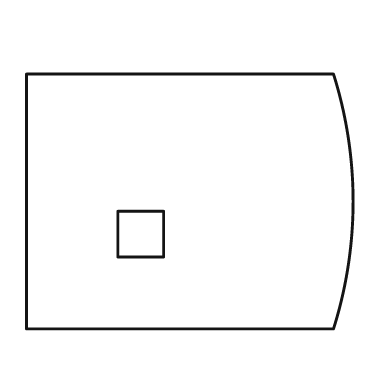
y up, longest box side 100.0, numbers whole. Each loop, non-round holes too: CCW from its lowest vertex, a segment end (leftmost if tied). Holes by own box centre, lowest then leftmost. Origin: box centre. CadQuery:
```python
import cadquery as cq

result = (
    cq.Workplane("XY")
    .moveTo(-50.0, -39.0)
    .lineTo(44.0, -39.0)
    .threePointArc((50.0, 0.0), (44.0, 39.0))
    .lineTo(-50.0, 39.0)
    .close()
    .moveTo(-22.0, -17.0)
    .lineTo(-8.0, -17.0)
    .lineTo(-8.0, -3.0)
    .lineTo(-22.0, -3.0)
    .close()
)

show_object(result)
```